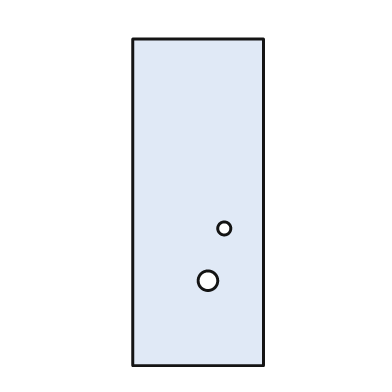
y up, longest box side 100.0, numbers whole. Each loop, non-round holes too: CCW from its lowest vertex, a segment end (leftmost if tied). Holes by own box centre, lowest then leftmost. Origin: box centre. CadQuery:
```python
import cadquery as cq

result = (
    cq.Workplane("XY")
    .moveTo(-20.0, -50.0)
    .lineTo(20.0, -50.0)
    .lineTo(20.0, 50.0)
    .lineTo(-20.0, 50.0)
    .close()
    .moveTo(3.0, -24.0)
    .circle(3.0)
    .moveTo(8.0, -8.0)
    .circle(2.0)
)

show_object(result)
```